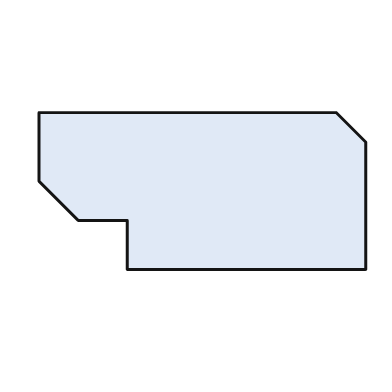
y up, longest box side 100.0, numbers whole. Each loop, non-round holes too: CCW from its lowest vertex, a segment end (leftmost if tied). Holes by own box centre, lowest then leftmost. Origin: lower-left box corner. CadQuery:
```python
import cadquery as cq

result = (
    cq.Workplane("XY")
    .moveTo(27.0, 0.0)
    .lineTo(100.0, 0.0)
    .lineTo(100.0, 39.0)
    .lineTo(91.0, 48.0)
    .lineTo(0.0, 48.0)
    .lineTo(0.0, 27.0)
    .lineTo(12.0, 15.0)
    .lineTo(27.0, 15.0)
    .close()
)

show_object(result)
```